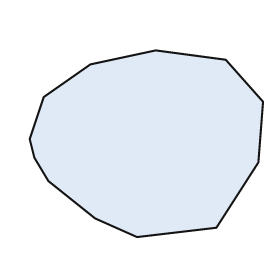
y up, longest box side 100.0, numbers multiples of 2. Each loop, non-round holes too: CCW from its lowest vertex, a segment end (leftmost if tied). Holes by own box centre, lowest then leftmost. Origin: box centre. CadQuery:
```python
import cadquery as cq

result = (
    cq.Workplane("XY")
    .moveTo(-4.0, -40.0)
    .lineTo(30.0, -36.0)
    .lineTo(48.0, -8.0)
    .lineTo(50.0, 18.0)
    .lineTo(34.0, 36.0)
    .lineTo(4.0, 40.0)
    .lineTo(-24.0, 34.0)
    .lineTo(-44.0, 20.0)
    .lineTo(-50.0, 2.0)
    .lineTo(-48.0, -6.0)
    .lineTo(-42.0, -16.0)
    .lineTo(-22.0, -32.0)
    .close()
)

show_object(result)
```